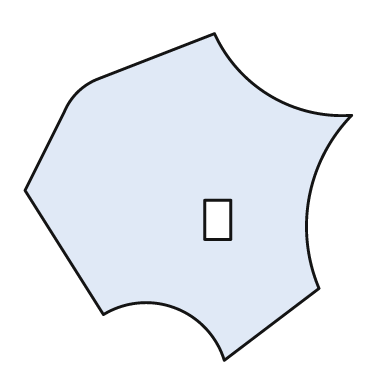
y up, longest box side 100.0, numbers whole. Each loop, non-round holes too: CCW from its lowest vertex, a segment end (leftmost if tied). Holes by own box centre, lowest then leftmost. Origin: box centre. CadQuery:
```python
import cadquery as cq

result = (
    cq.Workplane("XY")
    .moveTo(11.0, -50.0)
    .lineTo(40.0, -28.0)
    .threePointArc((37.0, 0.0), (50.0, 25.0))
    .threePointArc((25.0, 31.0), (8.0, 50.0))
    .lineTo(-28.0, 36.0)
    .threePointArc((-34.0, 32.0), (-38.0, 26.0))
    .lineTo(-50.0, 2.0)
    .lineTo(-26.0, -36.0)
    .threePointArc((-4.0, -34.0), (11.0, -50.0))
    .close()
    .moveTo(5.0, -13.0)
    .lineTo(13.0, -13.0)
    .lineTo(13.0, -1.0)
    .lineTo(5.0, -1.0)
    .close()
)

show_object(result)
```